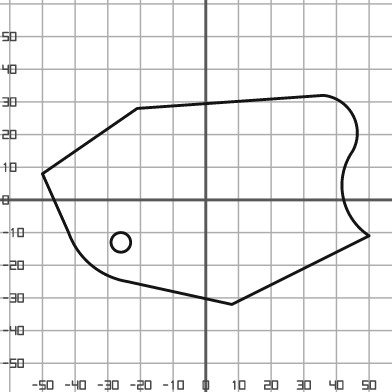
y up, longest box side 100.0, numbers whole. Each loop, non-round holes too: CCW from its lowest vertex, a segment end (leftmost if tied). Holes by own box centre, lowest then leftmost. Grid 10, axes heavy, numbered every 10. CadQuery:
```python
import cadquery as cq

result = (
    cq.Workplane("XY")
    .moveTo(8.0, -32.0)
    .lineTo(50.0, -11.0)
    .threePointArc((42.0, 1.0), (45.0, 15.0))
    .threePointArc((45.0, 26.0), (36.0, 32.0))
    .lineTo(-21.0, 28.0)
    .lineTo(-50.0, 8.0)
    .lineTo(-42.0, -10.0)
    .threePointArc((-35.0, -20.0), (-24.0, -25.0))
    .close()
    .moveTo(-26.0, -13.0)
    .circle(3.0)
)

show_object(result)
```